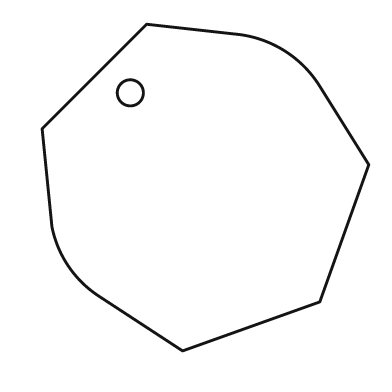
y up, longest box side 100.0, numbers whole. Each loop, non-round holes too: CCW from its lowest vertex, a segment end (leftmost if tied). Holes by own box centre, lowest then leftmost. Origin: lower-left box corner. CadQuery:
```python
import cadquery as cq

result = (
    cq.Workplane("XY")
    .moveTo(43.0, 0.0)
    .lineTo(85.0, 15.0)
    .lineTo(100.0, 57.0)
    .lineTo(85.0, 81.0)
    .threePointArc((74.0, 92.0), (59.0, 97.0))
    .lineTo(32.0, 100.0)
    .lineTo(0.0, 68.0)
    .lineTo(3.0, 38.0)
    .threePointArc((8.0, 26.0), (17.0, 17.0))
    .close()
    .moveTo(27.0, 79.0)
    .circle(4.0)
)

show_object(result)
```